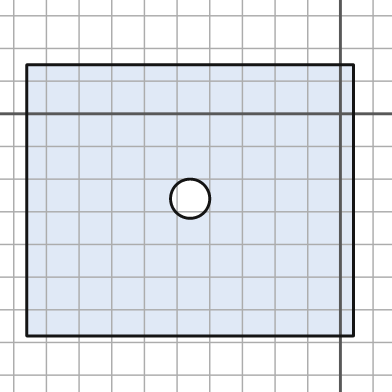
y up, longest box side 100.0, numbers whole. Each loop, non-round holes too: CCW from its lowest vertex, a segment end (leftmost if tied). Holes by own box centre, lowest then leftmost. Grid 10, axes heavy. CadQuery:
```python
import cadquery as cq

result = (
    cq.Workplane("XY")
    .moveTo(-96.0, -68.0)
    .lineTo(4.0, -68.0)
    .lineTo(4.0, 15.0)
    .lineTo(-96.0, 15.0)
    .close()
    .moveTo(-46.0, -26.0)
    .circle(6.0)
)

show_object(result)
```